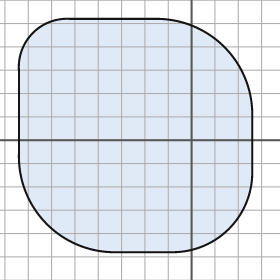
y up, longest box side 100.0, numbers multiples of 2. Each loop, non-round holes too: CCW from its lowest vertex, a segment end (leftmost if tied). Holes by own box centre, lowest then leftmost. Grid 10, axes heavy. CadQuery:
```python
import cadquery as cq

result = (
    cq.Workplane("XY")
    .moveTo(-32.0, -48.0)
    .lineTo(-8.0, -48.0)
    .threePointArc((16.0, -38.0), (26.0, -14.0))
    .lineTo(26.0, 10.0)
    .threePointArc((14.0, 40.0), (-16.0, 52.0))
    .lineTo(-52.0, 52.0)
    .threePointArc((-68.0, 46.0), (-74.0, 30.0))
    .lineTo(-74.0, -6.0)
    .threePointArc((-62.0, -36.0), (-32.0, -48.0))
    .close()
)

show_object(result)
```